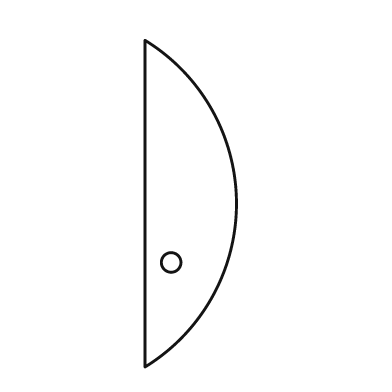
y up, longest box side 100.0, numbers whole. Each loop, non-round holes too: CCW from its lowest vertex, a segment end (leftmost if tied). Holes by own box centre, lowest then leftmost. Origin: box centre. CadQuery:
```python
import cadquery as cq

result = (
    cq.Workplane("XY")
    .moveTo(-14.0, -50.0)
    .threePointArc((14.0, 0.0), (-14.0, 50.0))
    .close()
    .moveTo(-6.0, -18.0)
    .circle(3.0)
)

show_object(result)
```